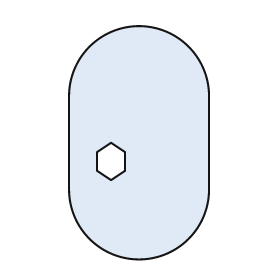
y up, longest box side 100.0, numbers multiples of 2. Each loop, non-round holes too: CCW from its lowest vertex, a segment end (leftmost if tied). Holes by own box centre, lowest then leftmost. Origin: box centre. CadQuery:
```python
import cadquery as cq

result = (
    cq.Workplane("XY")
    .moveTo(-30.0, -20.0)
    .threePointArc((0.0, -50.0), (30.0, -20.0))
    .lineTo(30.0, 20.0)
    .threePointArc((0.0, 50.0), (-30.0, 20.0))
    .close()
    .moveTo(-12.0, -16.0)
    .lineTo(-6.0, -12.0)
    .lineTo(-6.0, -4.0)
    .lineTo(-12.0, 0.0)
    .lineTo(-18.0, -4.0)
    .lineTo(-18.0, -12.0)
    .close()
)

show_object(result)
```